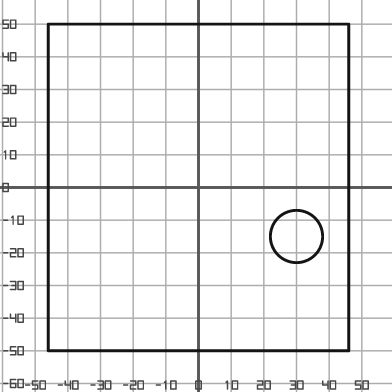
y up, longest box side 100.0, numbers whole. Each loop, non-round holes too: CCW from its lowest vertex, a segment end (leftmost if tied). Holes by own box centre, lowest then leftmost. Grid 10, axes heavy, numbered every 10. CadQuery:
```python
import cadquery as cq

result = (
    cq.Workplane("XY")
    .moveTo(-46.0, -50.0)
    .lineTo(46.0, -50.0)
    .lineTo(46.0, 50.0)
    .lineTo(-46.0, 50.0)
    .close()
    .moveTo(30.0, -15.0)
    .circle(8.0)
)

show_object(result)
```